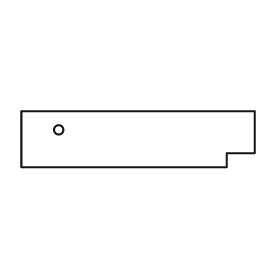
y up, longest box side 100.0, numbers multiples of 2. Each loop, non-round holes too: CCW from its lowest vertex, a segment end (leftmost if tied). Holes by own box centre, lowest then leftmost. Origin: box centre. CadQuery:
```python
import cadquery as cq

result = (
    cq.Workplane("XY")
    .moveTo(-50.0, -12.0)
    .lineTo(38.0, -12.0)
    .lineTo(38.0, -6.0)
    .lineTo(50.0, -6.0)
    .lineTo(50.0, 12.0)
    .lineTo(-50.0, 12.0)
    .close()
    .moveTo(-34.0, 4.0)
    .circle(2.0)
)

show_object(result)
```